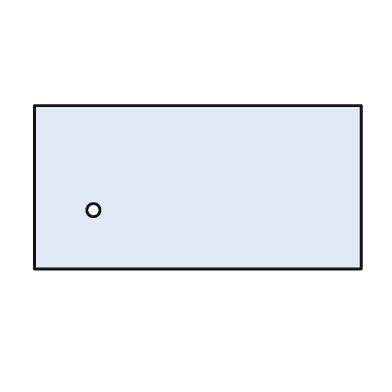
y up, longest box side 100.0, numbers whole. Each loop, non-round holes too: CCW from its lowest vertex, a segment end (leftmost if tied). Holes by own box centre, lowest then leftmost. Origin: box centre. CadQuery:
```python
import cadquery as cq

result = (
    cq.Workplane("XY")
    .moveTo(-50.0, -25.0)
    .lineTo(50.0, -25.0)
    .lineTo(50.0, 25.0)
    .lineTo(-50.0, 25.0)
    .close()
    .moveTo(-32.0, -7.0)
    .circle(2.0)
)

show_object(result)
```